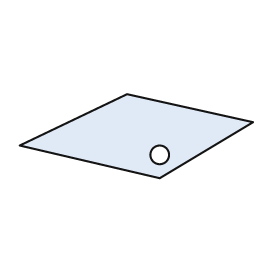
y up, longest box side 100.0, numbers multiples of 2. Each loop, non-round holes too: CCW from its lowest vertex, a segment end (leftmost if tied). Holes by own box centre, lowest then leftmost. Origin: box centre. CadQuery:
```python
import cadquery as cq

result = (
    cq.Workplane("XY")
    .moveTo(10.0, -18.0)
    .lineTo(50.0, 6.0)
    .lineTo(-4.0, 18.0)
    .lineTo(-50.0, -4.0)
    .close()
    .moveTo(10.0, -8.0)
    .circle(4.0)
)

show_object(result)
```